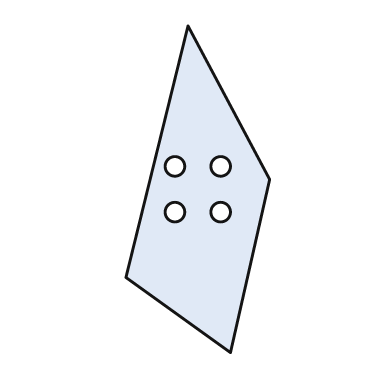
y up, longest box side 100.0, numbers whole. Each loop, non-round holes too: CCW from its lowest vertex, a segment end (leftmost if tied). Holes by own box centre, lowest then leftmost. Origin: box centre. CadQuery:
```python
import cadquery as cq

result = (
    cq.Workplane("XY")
    .moveTo(10.0, -50.0)
    .lineTo(22.0, 3.0)
    .lineTo(-3.0, 50.0)
    .lineTo(-22.0, -27.0)
    .close()
    .moveTo(-7.0, -7.0)
    .circle(3.0)
    .moveTo(7.0, -7.0)
    .circle(3.0)
    .moveTo(-7.0, 7.0)
    .circle(3.0)
    .moveTo(7.0, 7.0)
    .circle(3.0)
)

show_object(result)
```